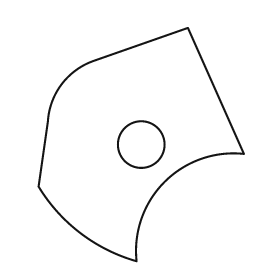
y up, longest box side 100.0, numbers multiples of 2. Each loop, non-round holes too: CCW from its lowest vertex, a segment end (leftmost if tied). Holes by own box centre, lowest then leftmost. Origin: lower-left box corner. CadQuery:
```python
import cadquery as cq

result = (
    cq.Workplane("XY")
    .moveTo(42.0, 0.0)
    .threePointArc((54.0, 34.0), (88.0, 46.0))
    .lineTo(64.0, 100.0)
    .lineTo(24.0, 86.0)
    .threePointArc((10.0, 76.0), (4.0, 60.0))
    .lineTo(0.0, 32.0)
    .threePointArc((18.0, 12.0), (42.0, 0.0))
    .close()
    .moveTo(44.0, 50.0)
    .circle(10.0)
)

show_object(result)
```